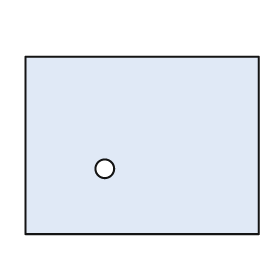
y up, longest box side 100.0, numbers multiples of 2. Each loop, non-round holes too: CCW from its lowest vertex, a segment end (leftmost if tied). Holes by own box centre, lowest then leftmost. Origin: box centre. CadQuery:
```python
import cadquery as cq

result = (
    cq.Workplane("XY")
    .moveTo(-50.0, -38.0)
    .lineTo(50.0, -38.0)
    .lineTo(50.0, 38.0)
    .lineTo(-50.0, 38.0)
    .close()
    .moveTo(-16.0, -10.0)
    .circle(4.0)
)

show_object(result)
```